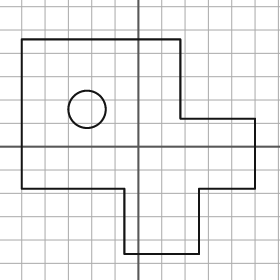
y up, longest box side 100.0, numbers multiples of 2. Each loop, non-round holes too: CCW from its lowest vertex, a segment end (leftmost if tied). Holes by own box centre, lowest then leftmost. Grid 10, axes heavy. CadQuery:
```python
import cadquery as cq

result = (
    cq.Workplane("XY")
    .moveTo(-6.0, -46.0)
    .lineTo(26.0, -46.0)
    .lineTo(26.0, -18.0)
    .lineTo(50.0, -18.0)
    .lineTo(50.0, 12.0)
    .lineTo(18.0, 12.0)
    .lineTo(18.0, 46.0)
    .lineTo(-50.0, 46.0)
    .lineTo(-50.0, -18.0)
    .lineTo(-6.0, -18.0)
    .close()
    .moveTo(-22.0, 16.0)
    .circle(8.0)
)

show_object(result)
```